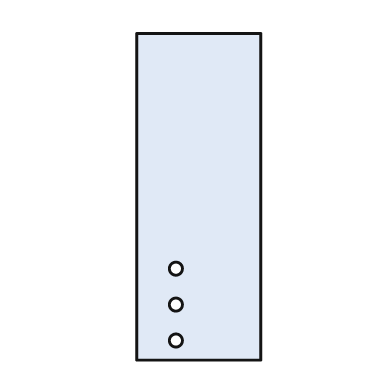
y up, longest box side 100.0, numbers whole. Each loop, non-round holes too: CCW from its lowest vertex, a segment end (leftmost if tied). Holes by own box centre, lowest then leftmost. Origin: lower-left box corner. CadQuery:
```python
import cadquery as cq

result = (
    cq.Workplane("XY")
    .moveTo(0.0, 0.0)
    .lineTo(38.0, 0.0)
    .lineTo(38.0, 100.0)
    .lineTo(0.0, 100.0)
    .close()
    .moveTo(12.0, 6.0)
    .circle(2.0)
    .moveTo(12.0, 17.0)
    .circle(2.0)
    .moveTo(12.0, 28.0)
    .circle(2.0)
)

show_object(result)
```